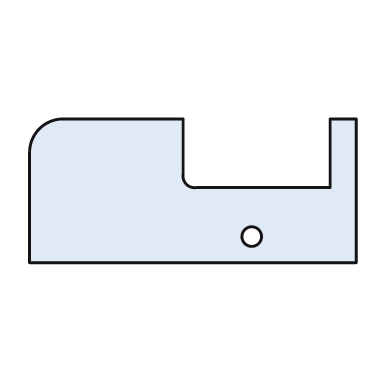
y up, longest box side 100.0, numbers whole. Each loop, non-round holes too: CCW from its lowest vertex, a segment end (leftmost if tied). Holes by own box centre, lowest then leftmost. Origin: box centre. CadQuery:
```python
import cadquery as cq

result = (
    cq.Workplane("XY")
    .moveTo(-50.0, -22.0)
    .lineTo(50.0, -22.0)
    .lineTo(50.0, 22.0)
    .lineTo(42.0, 22.0)
    .lineTo(42.0, 1.0)
    .lineTo(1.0, 1.0)
    .threePointArc((-2.0, 2.0), (-3.0, 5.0))
    .lineTo(-3.0, 22.0)
    .lineTo(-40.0, 22.0)
    .threePointArc((-47.0, 19.0), (-50.0, 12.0))
    .close()
    .moveTo(18.0, -14.0)
    .circle(3.0)
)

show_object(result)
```